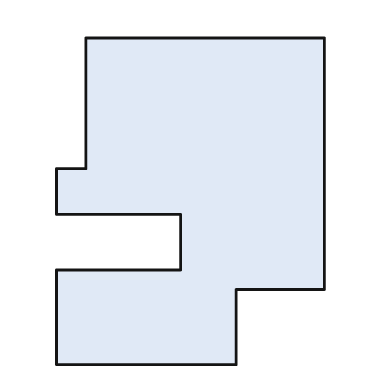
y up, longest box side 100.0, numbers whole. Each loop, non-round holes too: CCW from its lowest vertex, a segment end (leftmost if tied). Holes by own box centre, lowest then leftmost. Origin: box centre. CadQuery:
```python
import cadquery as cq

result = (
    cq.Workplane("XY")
    .moveTo(-41.0, -50.0)
    .lineTo(14.0, -50.0)
    .lineTo(14.0, -27.0)
    .lineTo(41.0, -27.0)
    .lineTo(41.0, 50.0)
    .lineTo(-32.0, 50.0)
    .lineTo(-32.0, 10.0)
    .lineTo(-41.0, 10.0)
    .lineTo(-41.0, -4.0)
    .lineTo(-3.0, -4.0)
    .lineTo(-3.0, -21.0)
    .lineTo(-41.0, -21.0)
    .close()
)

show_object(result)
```